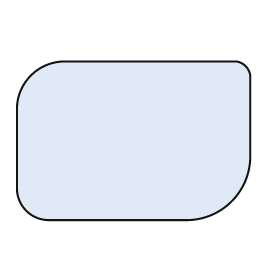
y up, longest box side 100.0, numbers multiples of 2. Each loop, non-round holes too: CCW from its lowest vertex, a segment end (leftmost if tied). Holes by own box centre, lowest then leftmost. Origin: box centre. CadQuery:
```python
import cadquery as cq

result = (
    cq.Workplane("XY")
    .moveTo(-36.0, -34.0)
    .lineTo(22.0, -34.0)
    .threePointArc((42.0, -26.0), (50.0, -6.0))
    .lineTo(50.0, 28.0)
    .threePointArc((48.0, 32.0), (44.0, 34.0))
    .lineTo(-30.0, 34.0)
    .threePointArc((-44.0, 28.0), (-50.0, 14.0))
    .lineTo(-50.0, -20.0)
    .threePointArc((-46.0, -30.0), (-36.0, -34.0))
    .close()
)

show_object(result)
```